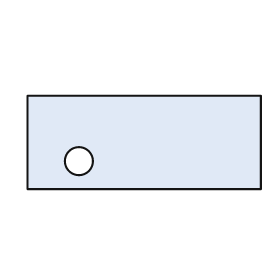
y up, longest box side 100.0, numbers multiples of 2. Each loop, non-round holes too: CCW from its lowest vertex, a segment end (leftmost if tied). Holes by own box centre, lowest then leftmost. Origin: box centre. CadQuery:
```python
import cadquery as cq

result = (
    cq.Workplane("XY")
    .moveTo(-50.0, -20.0)
    .lineTo(50.0, -20.0)
    .lineTo(50.0, 20.0)
    .lineTo(-50.0, 20.0)
    .close()
    .moveTo(-28.0, -8.0)
    .circle(6.0)
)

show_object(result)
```